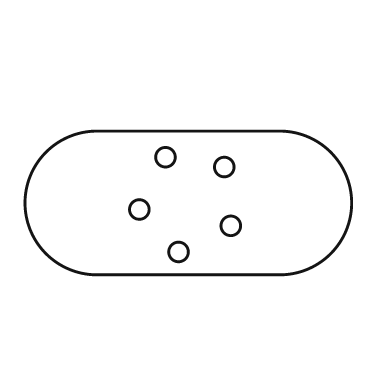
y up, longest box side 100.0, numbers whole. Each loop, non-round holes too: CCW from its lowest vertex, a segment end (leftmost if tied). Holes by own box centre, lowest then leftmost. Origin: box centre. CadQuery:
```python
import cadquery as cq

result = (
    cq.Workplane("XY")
    .moveTo(-28.0, -22.0)
    .lineTo(28.0, -22.0)
    .threePointArc((50.0, 0.0), (28.0, 22.0))
    .lineTo(-28.0, 22.0)
    .threePointArc((-50.0, 0.0), (-28.0, -22.0))
    .close()
    .moveTo(-3.0, -15.0)
    .circle(3.0)
    .moveTo(13.0, -7.0)
    .circle(3.0)
    .moveTo(-15.0, -2.0)
    .circle(3.0)
    .moveTo(11.0, 11.0)
    .circle(3.0)
    .moveTo(-7.0, 14.0)
    .circle(3.0)
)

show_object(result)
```